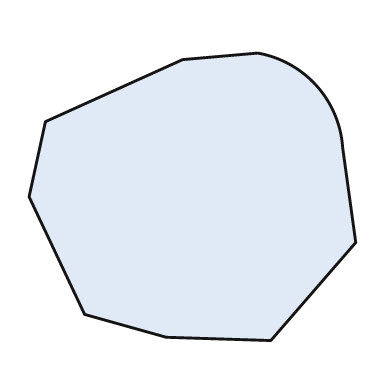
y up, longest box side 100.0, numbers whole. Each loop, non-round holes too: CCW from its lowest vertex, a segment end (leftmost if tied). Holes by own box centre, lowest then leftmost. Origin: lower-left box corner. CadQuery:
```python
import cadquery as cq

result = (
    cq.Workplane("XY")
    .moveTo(74.0, 0.0)
    .lineTo(100.0, 30.0)
    .lineTo(96.0, 59.0)
    .threePointArc((88.0, 78.0), (70.0, 88.0))
    .lineTo(47.0, 86.0)
    .lineTo(5.0, 67.0)
    .lineTo(0.0, 44.0)
    .lineTo(17.0, 8.0)
    .lineTo(42.0, 1.0)
    .close()
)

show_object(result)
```